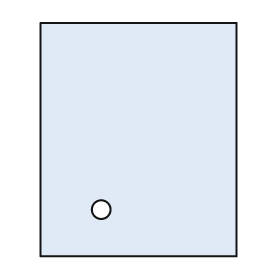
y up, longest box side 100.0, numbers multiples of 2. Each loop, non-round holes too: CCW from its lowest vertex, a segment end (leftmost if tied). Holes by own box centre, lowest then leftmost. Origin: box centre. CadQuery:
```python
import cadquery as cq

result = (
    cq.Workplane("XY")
    .moveTo(-42.0, -50.0)
    .lineTo(42.0, -50.0)
    .lineTo(42.0, 50.0)
    .lineTo(-42.0, 50.0)
    .close()
    .moveTo(-16.0, -30.0)
    .circle(4.0)
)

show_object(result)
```